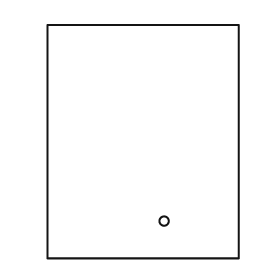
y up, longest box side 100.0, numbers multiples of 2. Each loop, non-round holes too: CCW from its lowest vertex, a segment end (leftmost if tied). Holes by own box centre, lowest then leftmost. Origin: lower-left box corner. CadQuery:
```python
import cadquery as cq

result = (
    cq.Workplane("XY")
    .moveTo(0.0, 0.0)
    .lineTo(82.0, 0.0)
    .lineTo(82.0, 100.0)
    .lineTo(0.0, 100.0)
    .close()
    .moveTo(50.0, 16.0)
    .circle(2.0)
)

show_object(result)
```